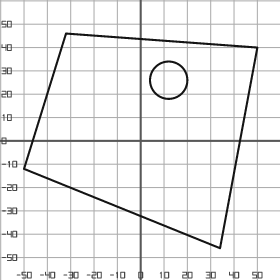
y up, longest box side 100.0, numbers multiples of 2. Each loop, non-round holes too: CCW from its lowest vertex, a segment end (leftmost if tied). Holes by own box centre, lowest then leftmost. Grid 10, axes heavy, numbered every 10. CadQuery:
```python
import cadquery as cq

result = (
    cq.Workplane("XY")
    .moveTo(34.0, -46.0)
    .lineTo(50.0, 40.0)
    .lineTo(-32.0, 46.0)
    .lineTo(-50.0, -12.0)
    .close()
    .moveTo(12.0, 26.0)
    .circle(8.0)
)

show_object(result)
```